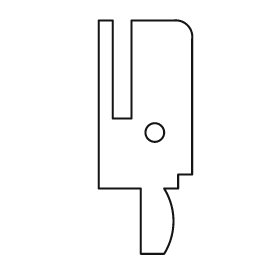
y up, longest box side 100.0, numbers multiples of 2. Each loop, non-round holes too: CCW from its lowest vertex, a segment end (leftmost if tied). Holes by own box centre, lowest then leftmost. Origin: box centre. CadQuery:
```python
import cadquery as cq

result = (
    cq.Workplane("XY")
    .moveTo(-2.0, -50.0)
    .lineTo(8.0, -50.0)
    .threePointArc((12.0, -36.0), (8.0, -22.0))
    .lineTo(14.0, -22.0)
    .lineTo(14.0, -16.0)
    .lineTo(20.0, -16.0)
    .lineTo(20.0, 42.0)
    .threePointArc((18.0, 48.0), (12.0, 50.0))
    .lineTo(-6.0, 50.0)
    .lineTo(-6.0, 8.0)
    .lineTo(-14.0, 8.0)
    .lineTo(-14.0, 50.0)
    .lineTo(-20.0, 50.0)
    .lineTo(-20.0, -22.0)
    .lineTo(-2.0, -22.0)
    .close()
    .moveTo(4.0, 2.0)
    .circle(4.0)
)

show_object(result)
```